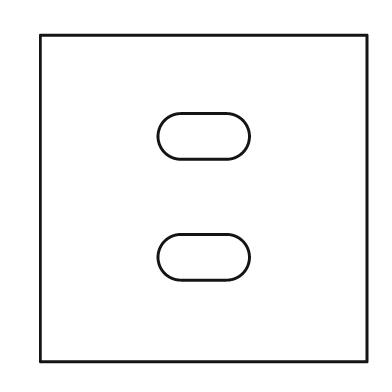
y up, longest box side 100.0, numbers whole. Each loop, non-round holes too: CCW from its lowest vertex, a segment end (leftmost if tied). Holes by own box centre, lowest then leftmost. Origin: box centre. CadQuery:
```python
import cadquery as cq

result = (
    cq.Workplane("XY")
    .moveTo(-50.0, -50.0)
    .lineTo(50.0, -50.0)
    .lineTo(50.0, 50.0)
    .lineTo(-50.0, 50.0)
    .close()
    .moveTo(-7.0, -25.0)
    .lineTo(7.0, -25.0)
    .threePointArc((14.0, -18.0), (7.0, -11.0))
    .lineTo(-7.0, -11.0)
    .threePointArc((-14.0, -18.0), (-7.0, -25.0))
    .close()
    .moveTo(-7.0, 12.0)
    .lineTo(7.0, 12.0)
    .threePointArc((14.0, 19.0), (7.0, 26.0))
    .lineTo(-7.0, 26.0)
    .threePointArc((-14.0, 19.0), (-7.0, 12.0))
    .close()
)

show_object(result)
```